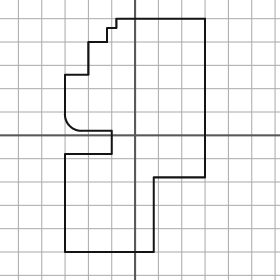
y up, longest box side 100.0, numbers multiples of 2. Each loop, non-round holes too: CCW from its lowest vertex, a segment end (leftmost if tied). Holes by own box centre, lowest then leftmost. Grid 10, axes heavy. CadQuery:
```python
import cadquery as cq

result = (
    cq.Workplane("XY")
    .moveTo(-30.0, -50.0)
    .lineTo(8.0, -50.0)
    .lineTo(8.0, -18.0)
    .lineTo(30.0, -18.0)
    .lineTo(30.0, 50.0)
    .lineTo(-8.0, 50.0)
    .lineTo(-8.0, 46.0)
    .lineTo(-12.0, 46.0)
    .lineTo(-12.0, 40.0)
    .lineTo(-20.0, 40.0)
    .lineTo(-20.0, 26.0)
    .lineTo(-30.0, 26.0)
    .lineTo(-30.0, 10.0)
    .threePointArc((-28.0, 4.0), (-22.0, 2.0))
    .lineTo(-10.0, 2.0)
    .lineTo(-10.0, -8.0)
    .lineTo(-30.0, -8.0)
    .close()
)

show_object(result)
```